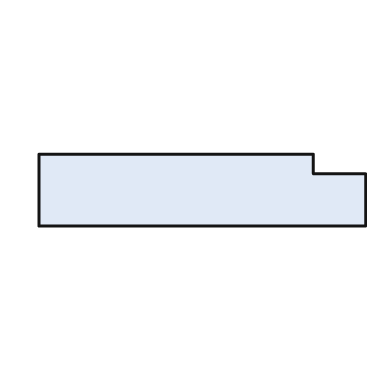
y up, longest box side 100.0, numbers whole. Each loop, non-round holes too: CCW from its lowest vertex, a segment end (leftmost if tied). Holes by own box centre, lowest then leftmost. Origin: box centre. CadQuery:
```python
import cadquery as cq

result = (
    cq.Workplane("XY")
    .moveTo(-50.0, -11.0)
    .lineTo(50.0, -11.0)
    .lineTo(50.0, 5.0)
    .lineTo(34.0, 5.0)
    .lineTo(34.0, 11.0)
    .lineTo(-50.0, 11.0)
    .close()
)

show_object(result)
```